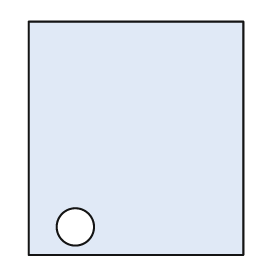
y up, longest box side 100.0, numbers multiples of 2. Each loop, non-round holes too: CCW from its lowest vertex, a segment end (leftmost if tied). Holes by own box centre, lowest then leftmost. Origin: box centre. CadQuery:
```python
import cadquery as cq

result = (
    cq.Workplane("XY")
    .moveTo(-46.0, -50.0)
    .lineTo(46.0, -50.0)
    .lineTo(46.0, 50.0)
    .lineTo(-46.0, 50.0)
    .close()
    .moveTo(-26.0, -38.0)
    .circle(8.0)
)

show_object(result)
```